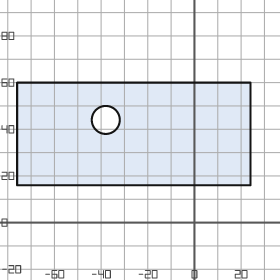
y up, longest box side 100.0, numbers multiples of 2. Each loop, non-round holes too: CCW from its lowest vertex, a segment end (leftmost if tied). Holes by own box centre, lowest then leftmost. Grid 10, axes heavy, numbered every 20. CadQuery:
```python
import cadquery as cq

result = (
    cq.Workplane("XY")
    .moveTo(-76.0, 16.0)
    .lineTo(24.0, 16.0)
    .lineTo(24.0, 60.0)
    .lineTo(-76.0, 60.0)
    .close()
    .moveTo(-38.0, 44.0)
    .circle(6.0)
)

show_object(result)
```